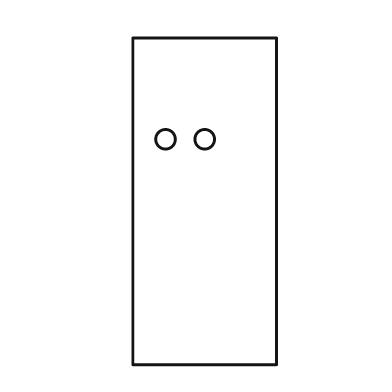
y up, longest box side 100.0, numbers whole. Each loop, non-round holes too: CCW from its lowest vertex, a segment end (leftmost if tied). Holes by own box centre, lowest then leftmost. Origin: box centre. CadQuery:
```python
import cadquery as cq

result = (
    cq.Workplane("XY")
    .moveTo(-22.0, -50.0)
    .lineTo(22.0, -50.0)
    .lineTo(22.0, 50.0)
    .lineTo(-22.0, 50.0)
    .close()
    .moveTo(-12.0, 19.0)
    .circle(3.0)
    .moveTo(0.0, 19.0)
    .circle(3.0)
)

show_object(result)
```